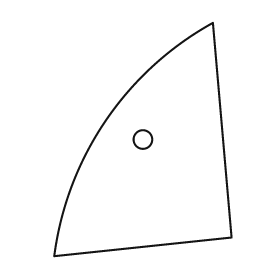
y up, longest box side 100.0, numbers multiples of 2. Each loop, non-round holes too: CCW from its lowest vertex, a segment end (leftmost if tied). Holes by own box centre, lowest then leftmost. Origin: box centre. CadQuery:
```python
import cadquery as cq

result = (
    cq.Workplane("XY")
    .moveTo(-38.0, -50.0)
    .lineTo(38.0, -42.0)
    .lineTo(30.0, 50.0)
    .threePointArc((-16.0, 8.0), (-38.0, -50.0))
    .close()
    .moveTo(0.0, 0.0)
    .circle(4.0)
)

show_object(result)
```